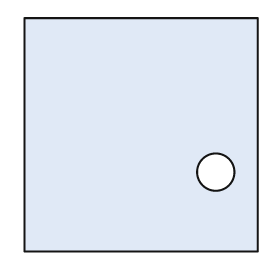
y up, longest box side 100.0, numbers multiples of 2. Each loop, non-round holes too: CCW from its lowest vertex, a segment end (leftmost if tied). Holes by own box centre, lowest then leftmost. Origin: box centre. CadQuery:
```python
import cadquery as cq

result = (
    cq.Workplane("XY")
    .moveTo(-50.0, -50.0)
    .lineTo(50.0, -50.0)
    .lineTo(50.0, 50.0)
    .lineTo(-50.0, 50.0)
    .close()
    .moveTo(32.0, -16.0)
    .circle(8.0)
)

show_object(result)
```